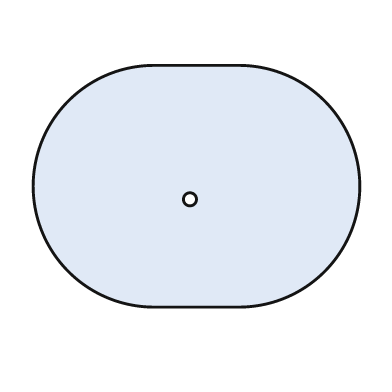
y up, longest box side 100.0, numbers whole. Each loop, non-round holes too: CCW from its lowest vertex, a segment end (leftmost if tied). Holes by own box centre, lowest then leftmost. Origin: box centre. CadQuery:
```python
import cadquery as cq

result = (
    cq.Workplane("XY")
    .moveTo(-13.0, -37.0)
    .lineTo(13.0, -37.0)
    .threePointArc((50.0, 0.0), (13.0, 37.0))
    .lineTo(-13.0, 37.0)
    .threePointArc((-50.0, 0.0), (-13.0, -37.0))
    .close()
    .moveTo(-2.0, -4.0)
    .circle(2.0)
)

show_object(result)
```